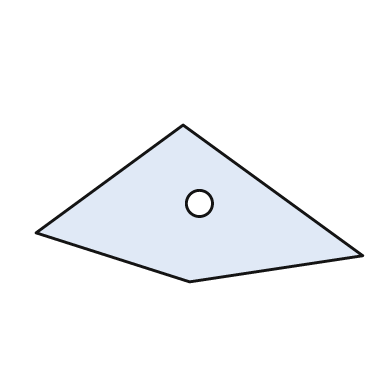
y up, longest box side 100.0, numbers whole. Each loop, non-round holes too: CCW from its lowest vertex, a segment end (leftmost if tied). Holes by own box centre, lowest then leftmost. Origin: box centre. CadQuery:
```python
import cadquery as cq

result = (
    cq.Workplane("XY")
    .moveTo(-3.0, -24.0)
    .lineTo(50.0, -16.0)
    .lineTo(-5.0, 24.0)
    .lineTo(-50.0, -9.0)
    .close()
    .moveTo(0.0, 0.0)
    .circle(4.0)
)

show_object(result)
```